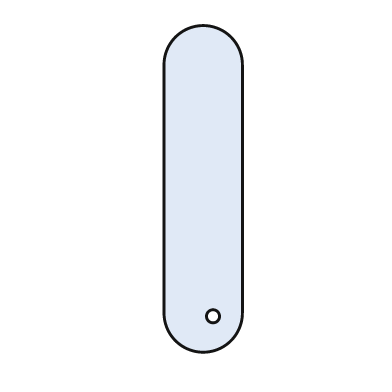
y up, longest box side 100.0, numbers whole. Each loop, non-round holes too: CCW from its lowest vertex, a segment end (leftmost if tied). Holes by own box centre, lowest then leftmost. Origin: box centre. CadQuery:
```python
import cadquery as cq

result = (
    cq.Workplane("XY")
    .moveTo(-12.0, -38.0)
    .threePointArc((0.0, -50.0), (12.0, -38.0))
    .lineTo(12.0, 38.0)
    .threePointArc((0.0, 50.0), (-12.0, 38.0))
    .close()
    .moveTo(3.0, -39.0)
    .circle(2.0)
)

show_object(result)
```